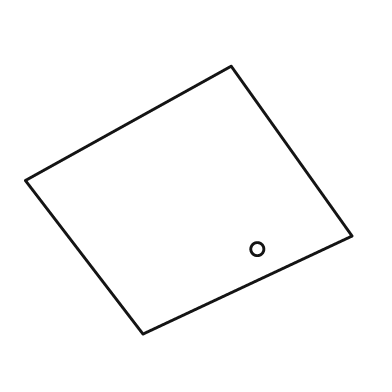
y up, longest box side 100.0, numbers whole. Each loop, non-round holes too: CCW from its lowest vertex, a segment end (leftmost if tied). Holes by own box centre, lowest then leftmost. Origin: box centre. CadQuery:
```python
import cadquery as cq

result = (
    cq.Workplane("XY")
    .moveTo(-14.0, -41.0)
    .lineTo(50.0, -11.0)
    .lineTo(13.0, 41.0)
    .lineTo(-50.0, 6.0)
    .close()
    .moveTo(21.0, -15.0)
    .circle(2.0)
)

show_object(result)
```